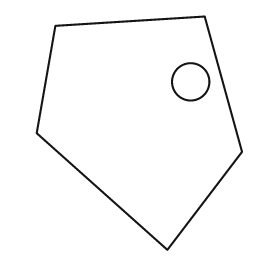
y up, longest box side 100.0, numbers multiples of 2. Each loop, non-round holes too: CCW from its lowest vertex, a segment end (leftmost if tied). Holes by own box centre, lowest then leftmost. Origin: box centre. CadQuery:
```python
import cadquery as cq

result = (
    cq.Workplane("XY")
    .moveTo(12.0, -50.0)
    .lineTo(44.0, -8.0)
    .lineTo(28.0, 50.0)
    .lineTo(-36.0, 46.0)
    .lineTo(-44.0, 0.0)
    .close()
    .moveTo(22.0, 22.0)
    .circle(8.0)
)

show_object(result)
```